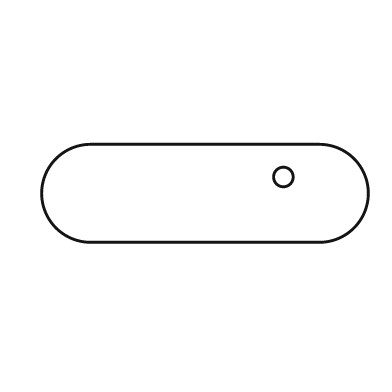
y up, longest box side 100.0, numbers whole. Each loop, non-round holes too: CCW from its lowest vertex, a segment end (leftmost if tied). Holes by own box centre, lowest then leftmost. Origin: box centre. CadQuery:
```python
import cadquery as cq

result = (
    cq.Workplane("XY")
    .moveTo(-35.0, -15.0)
    .lineTo(35.0, -15.0)
    .threePointArc((50.0, 0.0), (35.0, 15.0))
    .lineTo(-35.0, 15.0)
    .threePointArc((-50.0, 0.0), (-35.0, -15.0))
    .close()
    .moveTo(24.0, 5.0)
    .circle(3.0)
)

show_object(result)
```